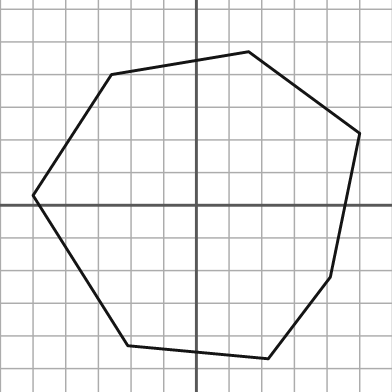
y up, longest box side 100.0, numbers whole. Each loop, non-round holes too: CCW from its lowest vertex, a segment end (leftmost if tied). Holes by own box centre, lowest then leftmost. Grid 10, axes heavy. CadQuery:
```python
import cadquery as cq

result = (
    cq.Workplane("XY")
    .moveTo(22.0, -47.0)
    .lineTo(41.0, -22.0)
    .lineTo(50.0, 22.0)
    .lineTo(16.0, 47.0)
    .lineTo(-26.0, 40.0)
    .lineTo(-50.0, 3.0)
    .lineTo(-21.0, -43.0)
    .close()
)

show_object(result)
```